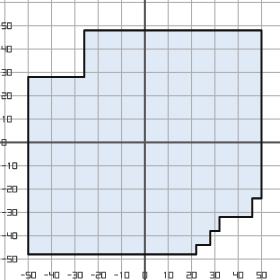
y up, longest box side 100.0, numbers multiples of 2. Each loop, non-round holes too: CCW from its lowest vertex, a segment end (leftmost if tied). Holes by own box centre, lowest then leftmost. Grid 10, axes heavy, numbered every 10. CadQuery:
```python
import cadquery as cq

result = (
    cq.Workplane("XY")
    .moveTo(-50.0, -48.0)
    .lineTo(22.0, -48.0)
    .lineTo(22.0, -44.0)
    .lineTo(28.0, -44.0)
    .lineTo(28.0, -38.0)
    .lineTo(32.0, -38.0)
    .lineTo(32.0, -32.0)
    .lineTo(46.0, -32.0)
    .lineTo(46.0, -24.0)
    .lineTo(50.0, -24.0)
    .lineTo(50.0, 48.0)
    .lineTo(-26.0, 48.0)
    .lineTo(-26.0, 28.0)
    .lineTo(-50.0, 28.0)
    .close()
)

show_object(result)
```